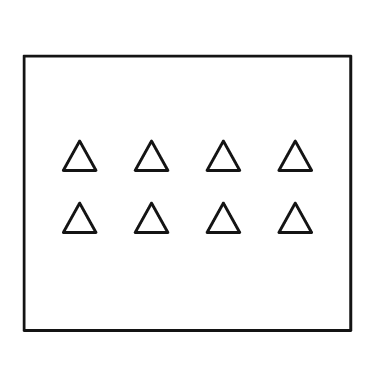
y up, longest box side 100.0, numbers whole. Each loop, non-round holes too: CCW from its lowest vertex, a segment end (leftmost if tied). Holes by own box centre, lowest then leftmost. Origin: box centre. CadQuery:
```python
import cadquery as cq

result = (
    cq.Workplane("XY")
    .moveTo(-50.0, -42.0)
    .lineTo(50.0, -42.0)
    .lineTo(50.0, 42.0)
    .lineTo(-50.0, 42.0)
    .close()
    .moveTo(-38.0, -12.0)
    .lineTo(-28.0, -12.0)
    .lineTo(-33.0, -3.0)
    .close()
    .moveTo(-16.0, -12.0)
    .lineTo(-6.0, -12.0)
    .lineTo(-11.0, -3.0)
    .close()
    .moveTo(6.0, -12.0)
    .lineTo(16.0, -12.0)
    .lineTo(11.0, -3.0)
    .close()
    .moveTo(28.0, -12.0)
    .lineTo(38.0, -12.0)
    .lineTo(33.0, -3.0)
    .close()
    .moveTo(-38.0, 7.0)
    .lineTo(-28.0, 7.0)
    .lineTo(-33.0, 16.0)
    .close()
    .moveTo(-16.0, 7.0)
    .lineTo(-6.0, 7.0)
    .lineTo(-11.0, 16.0)
    .close()
    .moveTo(6.0, 7.0)
    .lineTo(16.0, 7.0)
    .lineTo(11.0, 16.0)
    .close()
    .moveTo(28.0, 7.0)
    .lineTo(38.0, 7.0)
    .lineTo(33.0, 16.0)
    .close()
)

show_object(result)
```